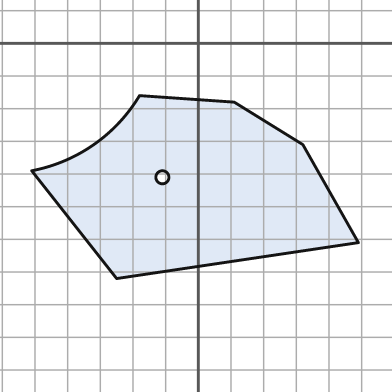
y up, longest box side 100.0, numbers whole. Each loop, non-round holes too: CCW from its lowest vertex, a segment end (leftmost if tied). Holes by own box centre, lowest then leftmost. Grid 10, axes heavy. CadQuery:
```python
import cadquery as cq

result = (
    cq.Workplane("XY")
    .moveTo(-25.0, -72.0)
    .lineTo(49.0, -61.0)
    .lineTo(32.0, -31.0)
    .lineTo(11.0, -18.0)
    .lineTo(-18.0, -16.0)
    .threePointArc((-32.0, -31.0), (-51.0, -39.0))
    .close()
    .moveTo(-11.0, -41.0)
    .circle(2.0)
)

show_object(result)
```